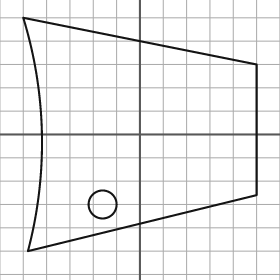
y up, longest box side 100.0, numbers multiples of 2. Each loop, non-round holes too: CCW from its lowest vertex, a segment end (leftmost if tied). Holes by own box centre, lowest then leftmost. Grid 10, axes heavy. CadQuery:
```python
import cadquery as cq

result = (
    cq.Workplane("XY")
    .moveTo(-48.0, -50.0)
    .lineTo(50.0, -26.0)
    .lineTo(50.0, 30.0)
    .lineTo(-50.0, 50.0)
    .threePointArc((-42.0, 0.0), (-48.0, -50.0))
    .close()
    .moveTo(-16.0, -30.0)
    .circle(6.0)
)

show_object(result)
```